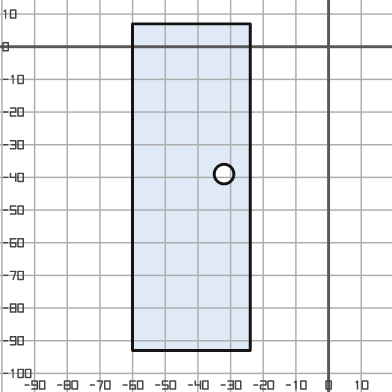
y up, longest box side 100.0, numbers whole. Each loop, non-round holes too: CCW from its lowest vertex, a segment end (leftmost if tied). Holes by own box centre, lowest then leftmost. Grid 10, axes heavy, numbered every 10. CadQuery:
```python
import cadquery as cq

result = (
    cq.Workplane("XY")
    .moveTo(-60.0, -93.0)
    .lineTo(-24.0, -93.0)
    .lineTo(-24.0, 7.0)
    .lineTo(-60.0, 7.0)
    .close()
    .moveTo(-32.0, -39.0)
    .circle(3.0)
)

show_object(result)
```